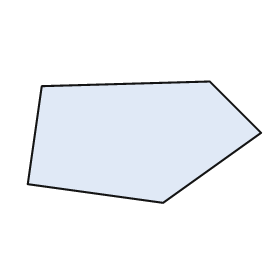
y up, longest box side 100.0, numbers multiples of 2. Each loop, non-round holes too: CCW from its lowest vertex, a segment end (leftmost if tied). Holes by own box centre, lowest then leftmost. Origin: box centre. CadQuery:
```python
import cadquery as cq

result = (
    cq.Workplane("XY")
    .moveTo(8.0, -26.0)
    .lineTo(50.0, 4.0)
    .lineTo(28.0, 26.0)
    .lineTo(-44.0, 24.0)
    .lineTo(-50.0, -18.0)
    .close()
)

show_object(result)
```